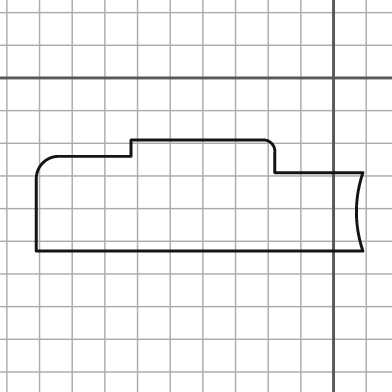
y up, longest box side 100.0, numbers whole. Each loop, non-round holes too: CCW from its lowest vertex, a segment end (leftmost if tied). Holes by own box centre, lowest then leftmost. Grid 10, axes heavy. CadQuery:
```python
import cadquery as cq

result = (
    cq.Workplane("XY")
    .moveTo(-91.0, -53.0)
    .lineTo(9.0, -53.0)
    .threePointArc((7.0, -41.0), (9.0, -29.0))
    .lineTo(-18.0, -29.0)
    .lineTo(-18.0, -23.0)
    .threePointArc((-19.0, -20.0), (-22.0, -19.0))
    .lineTo(-62.0, -19.0)
    .lineTo(-62.0, -24.0)
    .lineTo(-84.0, -24.0)
    .threePointArc((-89.0, -26.0), (-91.0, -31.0))
    .close()
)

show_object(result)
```